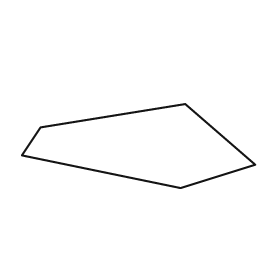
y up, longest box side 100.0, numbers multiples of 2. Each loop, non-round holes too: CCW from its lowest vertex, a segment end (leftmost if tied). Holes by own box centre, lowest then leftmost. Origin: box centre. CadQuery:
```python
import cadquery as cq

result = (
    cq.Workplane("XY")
    .moveTo(18.0, -18.0)
    .lineTo(50.0, -8.0)
    .lineTo(20.0, 18.0)
    .lineTo(-42.0, 8.0)
    .lineTo(-50.0, -4.0)
    .close()
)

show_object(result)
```